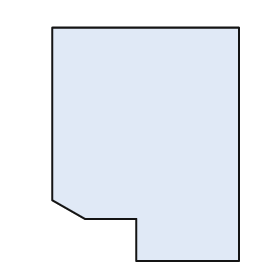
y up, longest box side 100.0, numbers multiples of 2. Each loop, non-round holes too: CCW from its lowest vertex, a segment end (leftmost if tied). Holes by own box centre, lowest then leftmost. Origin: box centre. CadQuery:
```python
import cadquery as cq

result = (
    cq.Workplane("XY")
    .moveTo(-4.0, -50.0)
    .lineTo(40.0, -50.0)
    .lineTo(40.0, 50.0)
    .lineTo(-40.0, 50.0)
    .lineTo(-40.0, -24.0)
    .lineTo(-26.0, -32.0)
    .lineTo(-4.0, -32.0)
    .close()
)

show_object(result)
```